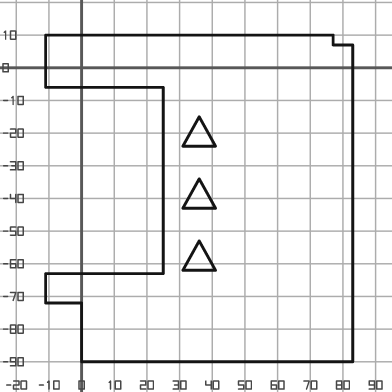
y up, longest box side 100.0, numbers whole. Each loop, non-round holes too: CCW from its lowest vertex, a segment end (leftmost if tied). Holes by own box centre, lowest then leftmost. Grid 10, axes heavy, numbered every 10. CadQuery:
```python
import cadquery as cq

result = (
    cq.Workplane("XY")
    .moveTo(0.0, -90.0)
    .lineTo(83.0, -90.0)
    .lineTo(83.0, 7.0)
    .lineTo(77.0, 7.0)
    .lineTo(77.0, 10.0)
    .lineTo(-11.0, 10.0)
    .lineTo(-11.0, -6.0)
    .lineTo(25.0, -6.0)
    .lineTo(25.0, -63.0)
    .lineTo(-11.0, -63.0)
    .lineTo(-11.0, -72.0)
    .lineTo(0.0, -72.0)
    .close()
    .moveTo(31.0, -62.0)
    .lineTo(41.0, -62.0)
    .lineTo(36.0, -53.0)
    .close()
    .moveTo(31.0, -43.0)
    .lineTo(41.0, -43.0)
    .lineTo(36.0, -34.0)
    .close()
    .moveTo(31.0, -24.0)
    .lineTo(41.0, -24.0)
    .lineTo(36.0, -15.0)
    .close()
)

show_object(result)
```